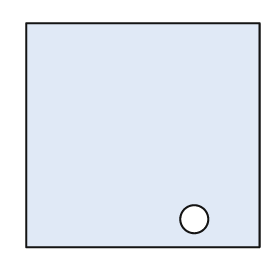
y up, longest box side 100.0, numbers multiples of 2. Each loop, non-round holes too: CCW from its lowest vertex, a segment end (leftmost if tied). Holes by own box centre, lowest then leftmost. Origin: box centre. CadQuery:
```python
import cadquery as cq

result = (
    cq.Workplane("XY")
    .moveTo(-50.0, -48.0)
    .lineTo(50.0, -48.0)
    .lineTo(50.0, 48.0)
    .lineTo(-50.0, 48.0)
    .close()
    .moveTo(22.0, -36.0)
    .circle(6.0)
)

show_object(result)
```